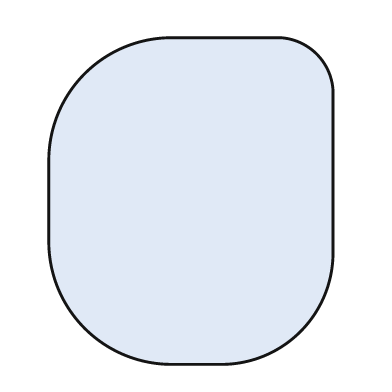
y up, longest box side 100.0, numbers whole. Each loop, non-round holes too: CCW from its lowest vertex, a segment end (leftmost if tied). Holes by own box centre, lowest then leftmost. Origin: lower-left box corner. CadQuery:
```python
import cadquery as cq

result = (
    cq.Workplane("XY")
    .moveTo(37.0, 0.0)
    .lineTo(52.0, 0.0)
    .threePointArc((77.0, 10.0), (87.0, 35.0))
    .lineTo(87.0, 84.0)
    .threePointArc((82.0, 95.0), (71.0, 100.0))
    .lineTo(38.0, 100.0)
    .threePointArc((11.0, 89.0), (0.0, 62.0))
    .lineTo(0.0, 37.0)
    .threePointArc((11.0, 11.0), (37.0, 0.0))
    .close()
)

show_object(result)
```